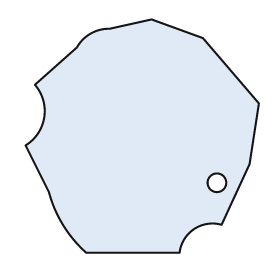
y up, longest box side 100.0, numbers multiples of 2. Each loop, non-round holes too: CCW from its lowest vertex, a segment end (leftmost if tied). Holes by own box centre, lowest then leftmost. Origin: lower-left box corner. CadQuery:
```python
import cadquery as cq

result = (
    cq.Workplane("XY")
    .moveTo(26.0, 0.0)
    .lineTo(66.0, 0.0)
    .threePointArc((72.0, 10.0), (84.0, 12.0))
    .lineTo(96.0, 38.0)
    .lineTo(100.0, 64.0)
    .lineTo(76.0, 92.0)
    .lineTo(54.0, 100.0)
    .lineTo(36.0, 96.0)
    .threePointArc((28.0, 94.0), (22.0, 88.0))
    .lineTo(4.0, 72.0)
    .threePointArc((8.0, 58.0), (0.0, 46.0))
    .lineTo(10.0, 26.0)
    .threePointArc((16.0, 12.0), (26.0, 0.0))
    .close()
    .moveTo(82.0, 30.0)
    .circle(4.0)
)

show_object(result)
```